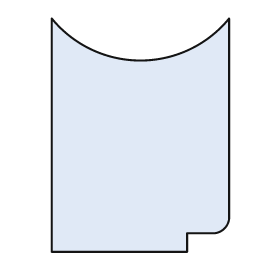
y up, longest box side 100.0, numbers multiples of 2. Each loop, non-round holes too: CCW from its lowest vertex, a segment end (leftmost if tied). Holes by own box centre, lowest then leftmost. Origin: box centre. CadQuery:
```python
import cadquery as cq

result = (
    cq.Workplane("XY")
    .moveTo(-38.0, -50.0)
    .lineTo(20.0, -50.0)
    .lineTo(20.0, -42.0)
    .lineTo(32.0, -42.0)
    .threePointArc((36.0, -40.0), (38.0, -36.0))
    .lineTo(38.0, 50.0)
    .threePointArc((0.0, 32.0), (-38.0, 50.0))
    .close()
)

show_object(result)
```